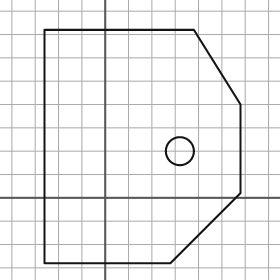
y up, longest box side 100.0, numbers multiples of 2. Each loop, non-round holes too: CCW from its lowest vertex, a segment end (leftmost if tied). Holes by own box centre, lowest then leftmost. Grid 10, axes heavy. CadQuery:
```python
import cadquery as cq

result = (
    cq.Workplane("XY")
    .moveTo(-26.0, -28.0)
    .lineTo(28.0, -28.0)
    .lineTo(58.0, 2.0)
    .lineTo(58.0, 40.0)
    .lineTo(38.0, 72.0)
    .lineTo(-26.0, 72.0)
    .close()
    .moveTo(32.0, 20.0)
    .circle(6.0)
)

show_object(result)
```